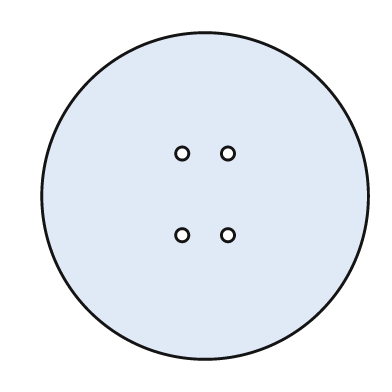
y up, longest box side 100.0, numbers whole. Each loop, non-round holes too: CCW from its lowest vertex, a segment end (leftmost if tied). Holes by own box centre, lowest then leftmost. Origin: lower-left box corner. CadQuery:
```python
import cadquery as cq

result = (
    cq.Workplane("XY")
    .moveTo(50.0, 50.0)
    .circle(50.0)
    .moveTo(43.0, 38.0)
    .circle(2.0)
    .moveTo(57.0, 38.0)
    .circle(2.0)
    .moveTo(43.0, 63.0)
    .circle(2.0)
    .moveTo(57.0, 63.0)
    .circle(2.0)
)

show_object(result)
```